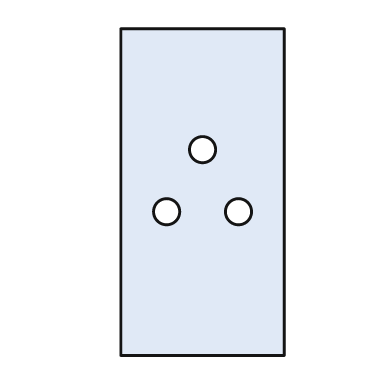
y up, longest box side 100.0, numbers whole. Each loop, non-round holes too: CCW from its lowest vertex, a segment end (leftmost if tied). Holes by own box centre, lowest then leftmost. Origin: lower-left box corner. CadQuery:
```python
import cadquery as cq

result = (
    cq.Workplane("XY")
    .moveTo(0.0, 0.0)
    .lineTo(50.0, 0.0)
    .lineTo(50.0, 100.0)
    .lineTo(0.0, 100.0)
    .close()
    .moveTo(14.0, 44.0)
    .circle(4.0)
    .moveTo(36.0, 44.0)
    .circle(4.0)
    .moveTo(25.0, 63.0)
    .circle(4.0)
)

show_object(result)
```